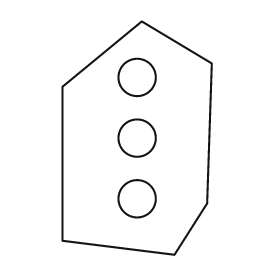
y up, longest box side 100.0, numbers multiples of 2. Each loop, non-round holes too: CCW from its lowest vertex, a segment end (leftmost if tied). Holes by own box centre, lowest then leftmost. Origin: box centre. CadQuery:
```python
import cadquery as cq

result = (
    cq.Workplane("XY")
    .moveTo(16.0, -50.0)
    .lineTo(30.0, -28.0)
    .lineTo(32.0, 32.0)
    .lineTo(2.0, 50.0)
    .lineTo(-32.0, 22.0)
    .lineTo(-32.0, -44.0)
    .close()
    .moveTo(0.0, -26.0)
    .circle(8.0)
    .moveTo(0.0, 0.0)
    .circle(8.0)
    .moveTo(0.0, 26.0)
    .circle(8.0)
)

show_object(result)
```